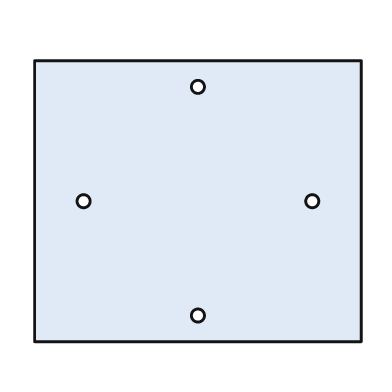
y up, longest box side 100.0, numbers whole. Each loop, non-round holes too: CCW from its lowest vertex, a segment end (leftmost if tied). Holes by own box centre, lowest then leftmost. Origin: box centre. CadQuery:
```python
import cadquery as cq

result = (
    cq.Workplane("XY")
    .moveTo(-50.0, -43.0)
    .lineTo(50.0, -43.0)
    .lineTo(50.0, 43.0)
    .lineTo(-50.0, 43.0)
    .close()
    .moveTo(0.0, -35.0)
    .circle(2.0)
    .moveTo(-35.0, 0.0)
    .circle(2.0)
    .moveTo(35.0, 0.0)
    .circle(2.0)
    .moveTo(0.0, 35.0)
    .circle(2.0)
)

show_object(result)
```